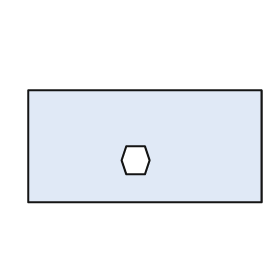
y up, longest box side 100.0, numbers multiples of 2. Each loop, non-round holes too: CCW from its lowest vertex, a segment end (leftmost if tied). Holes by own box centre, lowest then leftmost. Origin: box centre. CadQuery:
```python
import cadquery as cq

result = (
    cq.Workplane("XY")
    .moveTo(-50.0, -24.0)
    .lineTo(50.0, -24.0)
    .lineTo(50.0, 24.0)
    .lineTo(-50.0, 24.0)
    .close()
    .moveTo(-8.0, -12.0)
    .lineTo(0.0, -12.0)
    .lineTo(2.0, -6.0)
    .lineTo(0.0, 0.0)
    .lineTo(-8.0, 0.0)
    .lineTo(-10.0, -6.0)
    .close()
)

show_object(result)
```